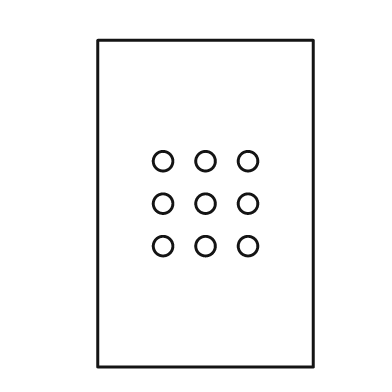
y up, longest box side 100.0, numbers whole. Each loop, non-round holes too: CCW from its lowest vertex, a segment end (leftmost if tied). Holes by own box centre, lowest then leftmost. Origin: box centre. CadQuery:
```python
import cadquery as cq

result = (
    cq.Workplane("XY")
    .moveTo(-33.0, -50.0)
    .lineTo(33.0, -50.0)
    .lineTo(33.0, 50.0)
    .lineTo(-33.0, 50.0)
    .close()
    .moveTo(-13.0, -13.0)
    .circle(3.0)
    .moveTo(0.0, -13.0)
    .circle(3.0)
    .moveTo(13.0, -13.0)
    .circle(3.0)
    .moveTo(-13.0, 0.0)
    .circle(3.0)
    .moveTo(0.0, 0.0)
    .circle(3.0)
    .moveTo(13.0, 0.0)
    .circle(3.0)
    .moveTo(-13.0, 13.0)
    .circle(3.0)
    .moveTo(0.0, 13.0)
    .circle(3.0)
    .moveTo(13.0, 13.0)
    .circle(3.0)
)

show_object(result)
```